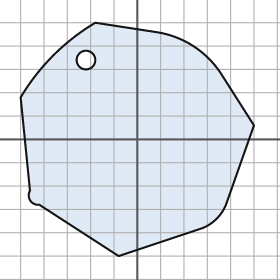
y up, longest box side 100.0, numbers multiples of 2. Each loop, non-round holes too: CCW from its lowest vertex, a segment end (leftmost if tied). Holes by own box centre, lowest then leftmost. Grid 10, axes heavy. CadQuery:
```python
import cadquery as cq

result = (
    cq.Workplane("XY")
    .moveTo(-8.0, -50.0)
    .lineTo(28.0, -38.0)
    .threePointArc((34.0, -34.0), (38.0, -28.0))
    .lineTo(50.0, 6.0)
    .lineTo(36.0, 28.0)
    .threePointArc((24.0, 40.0), (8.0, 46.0))
    .lineTo(-18.0, 50.0)
    .threePointArc((-36.0, 36.0), (-50.0, 18.0))
    .lineTo(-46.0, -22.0)
    .threePointArc((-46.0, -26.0), (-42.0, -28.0))
    .close()
    .moveTo(-22.0, 34.0)
    .circle(4.0)
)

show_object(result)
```